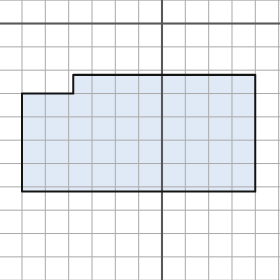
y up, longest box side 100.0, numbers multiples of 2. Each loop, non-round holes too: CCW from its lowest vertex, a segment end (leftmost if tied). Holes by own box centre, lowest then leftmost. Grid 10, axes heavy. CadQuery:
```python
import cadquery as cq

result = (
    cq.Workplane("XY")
    .moveTo(-60.0, -72.0)
    .lineTo(40.0, -72.0)
    .lineTo(40.0, -22.0)
    .lineTo(-38.0, -22.0)
    .lineTo(-38.0, -30.0)
    .lineTo(-60.0, -30.0)
    .close()
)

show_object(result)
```